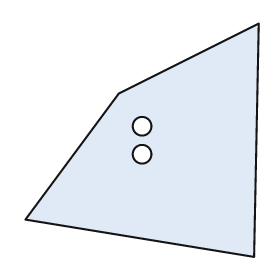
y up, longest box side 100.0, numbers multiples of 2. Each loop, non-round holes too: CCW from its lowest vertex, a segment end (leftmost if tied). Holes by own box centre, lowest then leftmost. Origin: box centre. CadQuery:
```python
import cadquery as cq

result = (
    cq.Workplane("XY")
    .moveTo(48.0, -50.0)
    .lineTo(50.0, 50.0)
    .lineTo(-10.0, 20.0)
    .lineTo(-50.0, -34.0)
    .close()
    .moveTo(0.0, -6.0)
    .circle(4.0)
    .moveTo(0.0, 6.0)
    .circle(4.0)
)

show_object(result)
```